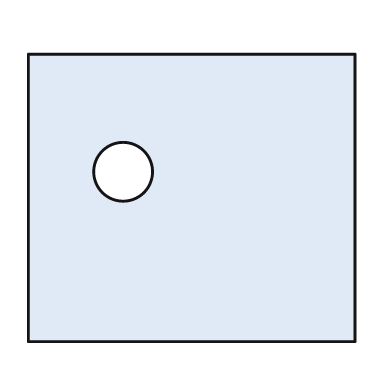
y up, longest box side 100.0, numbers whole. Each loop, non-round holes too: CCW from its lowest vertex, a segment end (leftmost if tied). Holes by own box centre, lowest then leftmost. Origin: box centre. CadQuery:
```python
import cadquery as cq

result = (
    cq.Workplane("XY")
    .moveTo(-50.0, -44.0)
    .lineTo(50.0, -44.0)
    .lineTo(50.0, 44.0)
    .lineTo(-50.0, 44.0)
    .close()
    .moveTo(-21.0, 8.0)
    .circle(9.0)
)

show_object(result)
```